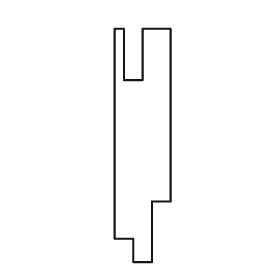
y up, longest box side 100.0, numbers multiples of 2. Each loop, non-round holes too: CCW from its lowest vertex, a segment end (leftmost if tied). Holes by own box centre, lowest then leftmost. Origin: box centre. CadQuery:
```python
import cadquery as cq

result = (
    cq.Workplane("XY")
    .moveTo(-4.0, -50.0)
    .lineTo(4.0, -50.0)
    .lineTo(4.0, -24.0)
    .lineTo(12.0, -24.0)
    .lineTo(12.0, 50.0)
    .lineTo(0.0, 50.0)
    .lineTo(0.0, 28.0)
    .lineTo(-8.0, 28.0)
    .lineTo(-8.0, 50.0)
    .lineTo(-12.0, 50.0)
    .lineTo(-12.0, -40.0)
    .lineTo(-4.0, -40.0)
    .close()
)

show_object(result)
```